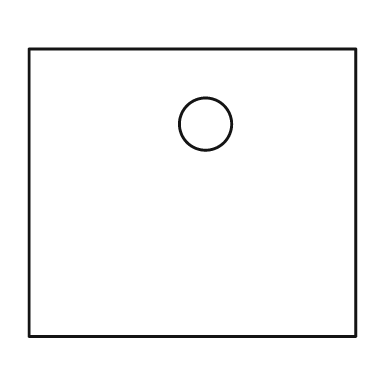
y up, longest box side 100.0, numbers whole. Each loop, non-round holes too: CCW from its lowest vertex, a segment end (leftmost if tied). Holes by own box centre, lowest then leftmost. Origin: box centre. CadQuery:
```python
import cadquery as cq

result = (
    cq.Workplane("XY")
    .moveTo(-50.0, -44.0)
    .lineTo(50.0, -44.0)
    .lineTo(50.0, 44.0)
    .lineTo(-50.0, 44.0)
    .close()
    .moveTo(4.0, 21.0)
    .circle(8.0)
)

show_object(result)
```